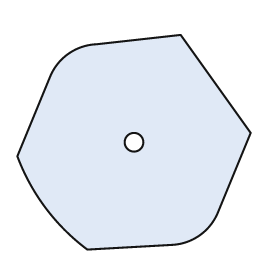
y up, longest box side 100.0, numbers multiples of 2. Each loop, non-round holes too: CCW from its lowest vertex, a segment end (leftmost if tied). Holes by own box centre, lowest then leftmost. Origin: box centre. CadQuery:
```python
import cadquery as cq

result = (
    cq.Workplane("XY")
    .moveTo(-20.0, -46.0)
    .lineTo(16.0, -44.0)
    .threePointArc((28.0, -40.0), (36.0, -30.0))
    .lineTo(50.0, 4.0)
    .lineTo(20.0, 46.0)
    .lineTo(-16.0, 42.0)
    .threePointArc((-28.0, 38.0), (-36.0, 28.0))
    .lineTo(-50.0, -6.0)
    .threePointArc((-38.0, -28.0), (-20.0, -46.0))
    .close()
    .moveTo(0.0, 0.0)
    .circle(4.0)
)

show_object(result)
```